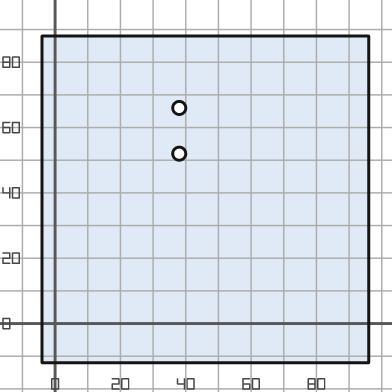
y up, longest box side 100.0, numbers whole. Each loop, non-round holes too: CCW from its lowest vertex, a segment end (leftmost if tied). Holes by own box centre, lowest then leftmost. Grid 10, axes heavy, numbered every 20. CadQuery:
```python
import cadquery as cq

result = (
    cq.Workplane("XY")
    .moveTo(-4.0, -12.0)
    .lineTo(96.0, -12.0)
    .lineTo(96.0, 88.0)
    .lineTo(-4.0, 88.0)
    .close()
    .moveTo(38.0, 52.0)
    .circle(2.0)
    .moveTo(38.0, 66.0)
    .circle(2.0)
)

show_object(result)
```